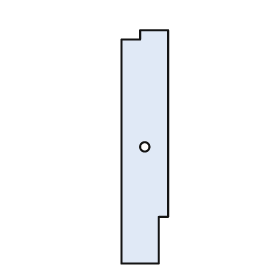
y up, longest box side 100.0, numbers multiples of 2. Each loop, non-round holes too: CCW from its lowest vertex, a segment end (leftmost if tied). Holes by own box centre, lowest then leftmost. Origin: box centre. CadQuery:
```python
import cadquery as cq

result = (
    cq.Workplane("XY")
    .moveTo(-10.0, -50.0)
    .lineTo(6.0, -50.0)
    .lineTo(6.0, -30.0)
    .lineTo(10.0, -30.0)
    .lineTo(10.0, 50.0)
    .lineTo(-2.0, 50.0)
    .lineTo(-2.0, 46.0)
    .lineTo(-10.0, 46.0)
    .close()
    .moveTo(0.0, 0.0)
    .circle(2.0)
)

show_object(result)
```